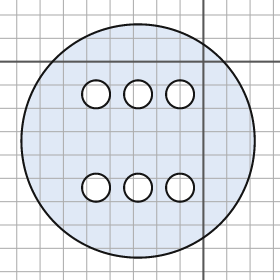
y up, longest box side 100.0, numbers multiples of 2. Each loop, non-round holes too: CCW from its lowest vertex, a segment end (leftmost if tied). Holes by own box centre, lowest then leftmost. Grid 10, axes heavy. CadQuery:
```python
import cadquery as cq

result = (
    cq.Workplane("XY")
    .moveTo(-28.0, -34.0)
    .circle(50.0)
    .moveTo(-46.0, -54.0)
    .circle(6.0)
    .moveTo(-28.0, -54.0)
    .circle(6.0)
    .moveTo(-10.0, -54.0)
    .circle(6.0)
    .moveTo(-46.0, -14.0)
    .circle(6.0)
    .moveTo(-28.0, -14.0)
    .circle(6.0)
    .moveTo(-10.0, -14.0)
    .circle(6.0)
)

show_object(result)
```